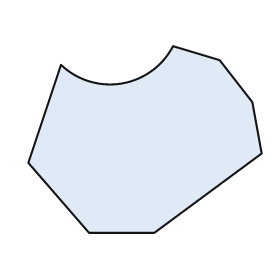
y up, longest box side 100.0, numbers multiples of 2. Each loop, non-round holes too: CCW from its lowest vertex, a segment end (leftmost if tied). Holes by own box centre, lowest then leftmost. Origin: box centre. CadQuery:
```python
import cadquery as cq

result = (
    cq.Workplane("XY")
    .moveTo(-24.0, -40.0)
    .lineTo(4.0, -40.0)
    .lineTo(50.0, -6.0)
    .lineTo(46.0, 16.0)
    .lineTo(32.0, 34.0)
    .lineTo(12.0, 40.0)
    .threePointArc((-10.0, 24.0), (-36.0, 32.0))
    .lineTo(-50.0, -10.0)
    .close()
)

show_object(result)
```